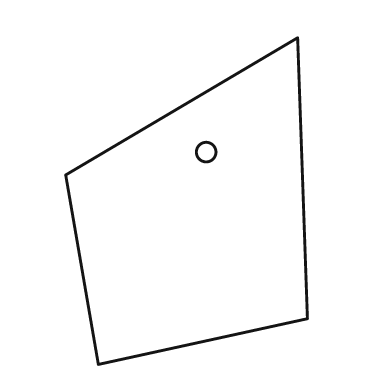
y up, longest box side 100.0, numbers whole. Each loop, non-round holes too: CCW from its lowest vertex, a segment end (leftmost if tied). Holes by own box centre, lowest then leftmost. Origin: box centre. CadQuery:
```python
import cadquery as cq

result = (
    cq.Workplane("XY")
    .moveTo(-27.0, -50.0)
    .lineTo(37.0, -36.0)
    .lineTo(34.0, 50.0)
    .lineTo(-37.0, 8.0)
    .close()
    .moveTo(6.0, 15.0)
    .circle(3.0)
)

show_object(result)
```